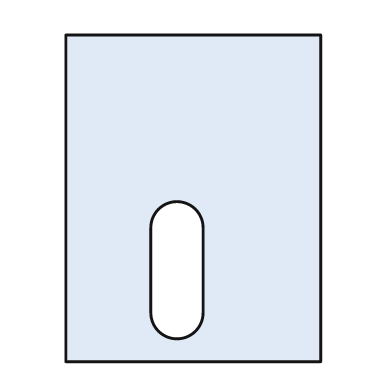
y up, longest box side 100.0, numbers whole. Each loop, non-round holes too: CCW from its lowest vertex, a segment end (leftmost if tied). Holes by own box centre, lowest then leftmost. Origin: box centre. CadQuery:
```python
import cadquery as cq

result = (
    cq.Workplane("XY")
    .moveTo(-39.0, -50.0)
    .lineTo(39.0, -50.0)
    .lineTo(39.0, 50.0)
    .lineTo(-39.0, 50.0)
    .close()
    .moveTo(-13.0, -35.0)
    .threePointArc((-5.0, -43.0), (3.0, -35.0))
    .lineTo(3.0, -9.0)
    .threePointArc((-5.0, -1.0), (-13.0, -9.0))
    .close()
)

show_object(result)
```